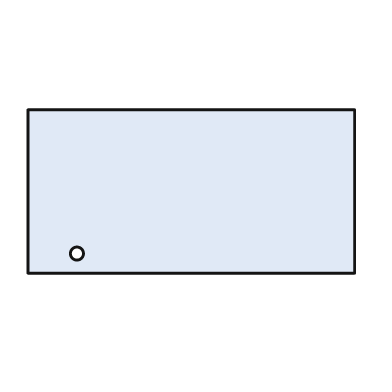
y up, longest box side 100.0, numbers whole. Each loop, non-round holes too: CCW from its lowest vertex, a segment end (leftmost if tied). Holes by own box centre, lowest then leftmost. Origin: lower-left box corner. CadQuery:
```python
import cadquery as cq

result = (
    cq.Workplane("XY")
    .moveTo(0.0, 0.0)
    .lineTo(100.0, 0.0)
    .lineTo(100.0, 50.0)
    .lineTo(0.0, 50.0)
    .close()
    .moveTo(15.0, 6.0)
    .circle(2.0)
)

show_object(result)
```